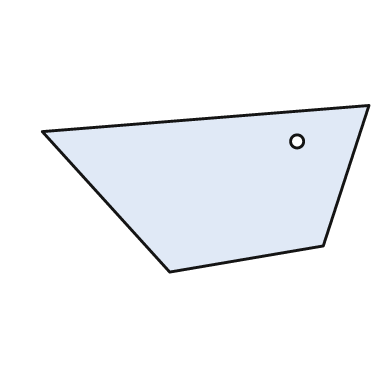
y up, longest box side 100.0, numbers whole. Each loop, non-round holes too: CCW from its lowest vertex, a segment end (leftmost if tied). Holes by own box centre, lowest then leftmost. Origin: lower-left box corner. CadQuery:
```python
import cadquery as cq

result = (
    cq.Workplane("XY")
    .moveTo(39.0, 0.0)
    .lineTo(86.0, 8.0)
    .lineTo(100.0, 51.0)
    .lineTo(0.0, 43.0)
    .close()
    .moveTo(78.0, 40.0)
    .circle(2.0)
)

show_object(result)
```